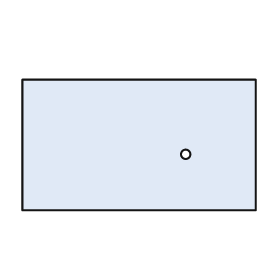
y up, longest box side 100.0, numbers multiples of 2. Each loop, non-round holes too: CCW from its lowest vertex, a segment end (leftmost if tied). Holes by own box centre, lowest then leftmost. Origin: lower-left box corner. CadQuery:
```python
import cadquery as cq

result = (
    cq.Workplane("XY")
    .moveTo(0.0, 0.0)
    .lineTo(100.0, 0.0)
    .lineTo(100.0, 56.0)
    .lineTo(0.0, 56.0)
    .close()
    .moveTo(70.0, 24.0)
    .circle(2.0)
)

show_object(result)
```